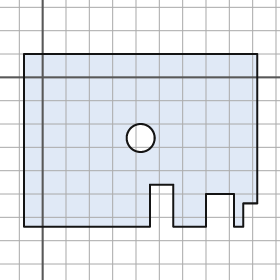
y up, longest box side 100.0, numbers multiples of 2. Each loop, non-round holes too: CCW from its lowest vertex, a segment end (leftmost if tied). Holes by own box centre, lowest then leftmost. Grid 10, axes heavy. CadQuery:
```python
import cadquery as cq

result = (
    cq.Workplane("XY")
    .moveTo(-8.0, -64.0)
    .lineTo(46.0, -64.0)
    .lineTo(46.0, -46.0)
    .lineTo(56.0, -46.0)
    .lineTo(56.0, -64.0)
    .lineTo(70.0, -64.0)
    .lineTo(70.0, -50.0)
    .lineTo(82.0, -50.0)
    .lineTo(82.0, -64.0)
    .lineTo(86.0, -64.0)
    .lineTo(86.0, -54.0)
    .lineTo(92.0, -54.0)
    .lineTo(92.0, 10.0)
    .lineTo(-8.0, 10.0)
    .close()
    .moveTo(42.0, -26.0)
    .circle(6.0)
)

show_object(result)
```